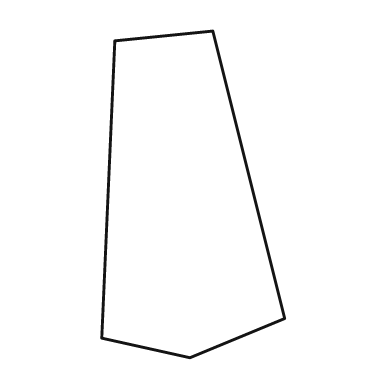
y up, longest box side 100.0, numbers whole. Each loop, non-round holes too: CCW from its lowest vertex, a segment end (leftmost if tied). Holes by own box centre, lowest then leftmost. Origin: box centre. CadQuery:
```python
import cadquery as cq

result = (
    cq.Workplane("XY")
    .moveTo(-1.0, -50.0)
    .lineTo(28.0, -38.0)
    .lineTo(6.0, 50.0)
    .lineTo(-24.0, 47.0)
    .lineTo(-28.0, -44.0)
    .close()
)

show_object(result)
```